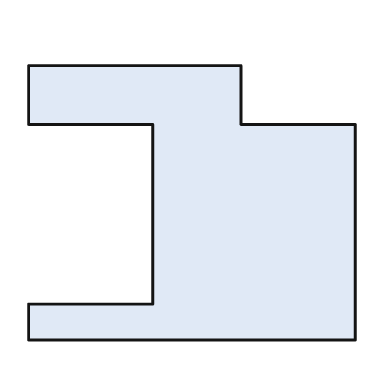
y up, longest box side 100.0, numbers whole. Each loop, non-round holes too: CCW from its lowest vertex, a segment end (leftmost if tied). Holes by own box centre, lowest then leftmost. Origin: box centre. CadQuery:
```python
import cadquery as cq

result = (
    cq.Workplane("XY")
    .moveTo(-50.0, -42.0)
    .lineTo(50.0, -42.0)
    .lineTo(50.0, 24.0)
    .lineTo(15.0, 24.0)
    .lineTo(15.0, 42.0)
    .lineTo(-50.0, 42.0)
    .lineTo(-50.0, 24.0)
    .lineTo(-12.0, 24.0)
    .lineTo(-12.0, -31.0)
    .lineTo(-50.0, -31.0)
    .close()
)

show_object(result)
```